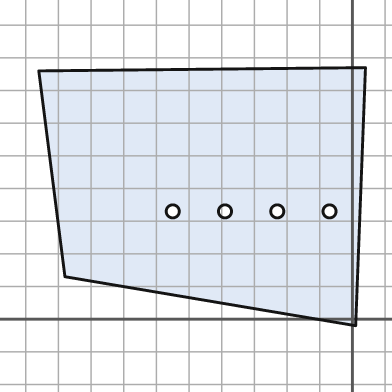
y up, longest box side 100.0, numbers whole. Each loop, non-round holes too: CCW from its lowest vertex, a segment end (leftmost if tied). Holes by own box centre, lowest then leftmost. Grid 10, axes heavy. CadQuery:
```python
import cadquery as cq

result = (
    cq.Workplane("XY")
    .moveTo(1.0, -2.0)
    .lineTo(4.0, 77.0)
    .lineTo(-96.0, 76.0)
    .lineTo(-88.0, 13.0)
    .close()
    .moveTo(-55.0, 33.0)
    .circle(2.0)
    .moveTo(-39.0, 33.0)
    .circle(2.0)
    .moveTo(-23.0, 33.0)
    .circle(2.0)
    .moveTo(-7.0, 33.0)
    .circle(2.0)
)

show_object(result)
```